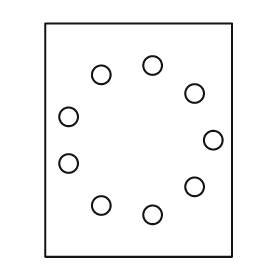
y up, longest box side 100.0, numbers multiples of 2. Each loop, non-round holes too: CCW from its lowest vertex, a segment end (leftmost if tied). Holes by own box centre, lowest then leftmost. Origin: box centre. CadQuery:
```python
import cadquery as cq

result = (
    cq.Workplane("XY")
    .moveTo(-40.0, -50.0)
    .lineTo(40.0, -50.0)
    .lineTo(40.0, 50.0)
    .lineTo(-40.0, 50.0)
    .close()
    .moveTo(6.0, -32.0)
    .circle(4.0)
    .moveTo(-16.0, -28.0)
    .circle(4.0)
    .moveTo(24.0, -20.0)
    .circle(4.0)
    .moveTo(-30.0, -10.0)
    .circle(4.0)
    .moveTo(32.0, 0.0)
    .circle(4.0)
    .moveTo(-30.0, 10.0)
    .circle(4.0)
    .moveTo(24.0, 20.0)
    .circle(4.0)
    .moveTo(-16.0, 28.0)
    .circle(4.0)
    .moveTo(6.0, 32.0)
    .circle(4.0)
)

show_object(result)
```